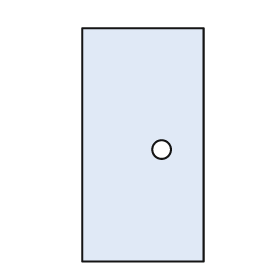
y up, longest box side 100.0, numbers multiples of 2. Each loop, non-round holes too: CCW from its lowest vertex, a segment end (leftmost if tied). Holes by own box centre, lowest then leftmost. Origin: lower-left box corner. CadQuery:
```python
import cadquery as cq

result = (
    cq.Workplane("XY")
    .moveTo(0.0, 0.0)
    .lineTo(52.0, 0.0)
    .lineTo(52.0, 100.0)
    .lineTo(0.0, 100.0)
    .close()
    .moveTo(34.0, 48.0)
    .circle(4.0)
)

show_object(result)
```